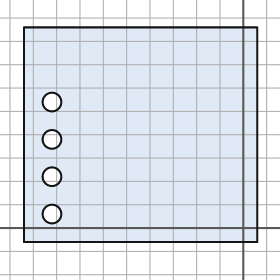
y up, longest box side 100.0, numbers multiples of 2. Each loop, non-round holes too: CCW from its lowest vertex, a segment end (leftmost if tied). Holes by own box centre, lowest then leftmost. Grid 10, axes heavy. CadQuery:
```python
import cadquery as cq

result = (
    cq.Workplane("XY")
    .moveTo(-94.0, -6.0)
    .lineTo(6.0, -6.0)
    .lineTo(6.0, 86.0)
    .lineTo(-94.0, 86.0)
    .close()
    .moveTo(-82.0, 6.0)
    .circle(4.0)
    .moveTo(-82.0, 22.0)
    .circle(4.0)
    .moveTo(-82.0, 38.0)
    .circle(4.0)
    .moveTo(-82.0, 54.0)
    .circle(4.0)
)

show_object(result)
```